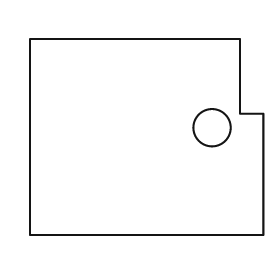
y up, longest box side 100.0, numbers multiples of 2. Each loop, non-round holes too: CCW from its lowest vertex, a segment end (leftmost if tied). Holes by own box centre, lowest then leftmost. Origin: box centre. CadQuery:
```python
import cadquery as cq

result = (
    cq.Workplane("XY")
    .moveTo(-50.0, -42.0)
    .lineTo(50.0, -42.0)
    .lineTo(50.0, 10.0)
    .lineTo(40.0, 10.0)
    .lineTo(40.0, 42.0)
    .lineTo(-50.0, 42.0)
    .close()
    .moveTo(28.0, 4.0)
    .circle(8.0)
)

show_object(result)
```